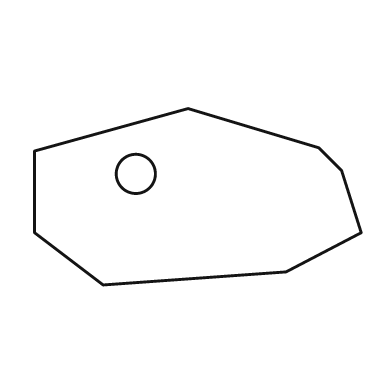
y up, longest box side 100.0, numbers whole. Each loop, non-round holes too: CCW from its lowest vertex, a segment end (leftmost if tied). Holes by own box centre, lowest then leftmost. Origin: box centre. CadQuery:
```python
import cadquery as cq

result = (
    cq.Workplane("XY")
    .moveTo(-29.0, -27.0)
    .lineTo(27.0, -23.0)
    .lineTo(50.0, -11.0)
    .lineTo(44.0, 8.0)
    .lineTo(37.0, 15.0)
    .lineTo(-3.0, 27.0)
    .lineTo(-50.0, 14.0)
    .lineTo(-50.0, -11.0)
    .close()
    .moveTo(-19.0, 7.0)
    .circle(6.0)
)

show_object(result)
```